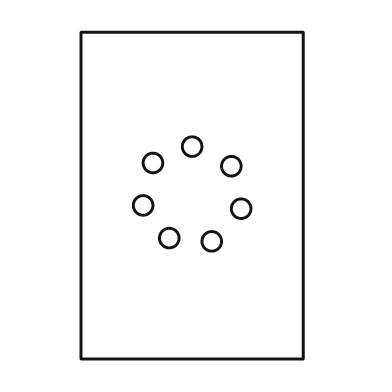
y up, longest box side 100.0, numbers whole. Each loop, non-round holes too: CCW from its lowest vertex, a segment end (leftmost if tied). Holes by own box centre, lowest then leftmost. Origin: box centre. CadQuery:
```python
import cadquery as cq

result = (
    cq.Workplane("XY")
    .moveTo(-34.0, -50.0)
    .lineTo(34.0, -50.0)
    .lineTo(34.0, 50.0)
    .lineTo(-34.0, 50.0)
    .close()
    .moveTo(6.0, -14.0)
    .circle(3.0)
    .moveTo(-7.0, -13.0)
    .circle(3.0)
    .moveTo(15.0, -4.0)
    .circle(3.0)
    .moveTo(-15.0, -3.0)
    .circle(3.0)
    .moveTo(12.0, 9.0)
    .circle(3.0)
    .moveTo(-12.0, 10.0)
    .circle(3.0)
    .moveTo(0.0, 15.0)
    .circle(3.0)
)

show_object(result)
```